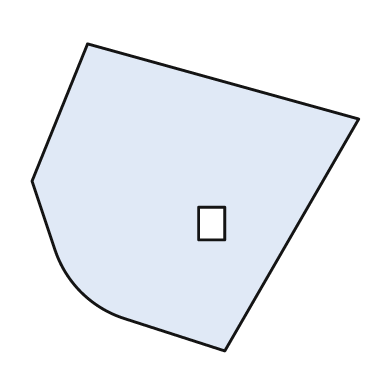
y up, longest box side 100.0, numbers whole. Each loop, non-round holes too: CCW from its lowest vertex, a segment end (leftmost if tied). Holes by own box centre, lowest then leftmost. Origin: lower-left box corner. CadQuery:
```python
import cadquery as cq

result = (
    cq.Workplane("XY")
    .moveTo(59.0, 0.0)
    .lineTo(100.0, 71.0)
    .lineTo(17.0, 94.0)
    .lineTo(0.0, 52.0)
    .lineTo(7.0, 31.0)
    .threePointArc((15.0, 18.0), (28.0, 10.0))
    .close()
    .moveTo(51.0, 34.0)
    .lineTo(59.0, 34.0)
    .lineTo(59.0, 44.0)
    .lineTo(51.0, 44.0)
    .close()
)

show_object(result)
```